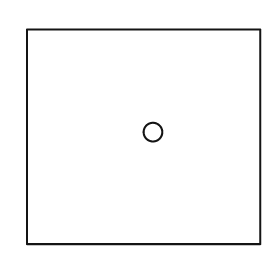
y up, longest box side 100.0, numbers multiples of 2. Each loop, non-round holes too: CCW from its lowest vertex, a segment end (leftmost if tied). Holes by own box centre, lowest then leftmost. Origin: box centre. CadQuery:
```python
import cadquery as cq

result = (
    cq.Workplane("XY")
    .moveTo(-50.0, -46.0)
    .lineTo(50.0, -46.0)
    .lineTo(50.0, 46.0)
    .lineTo(-50.0, 46.0)
    .close()
    .moveTo(4.0, 2.0)
    .circle(4.0)
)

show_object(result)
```